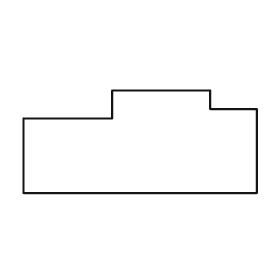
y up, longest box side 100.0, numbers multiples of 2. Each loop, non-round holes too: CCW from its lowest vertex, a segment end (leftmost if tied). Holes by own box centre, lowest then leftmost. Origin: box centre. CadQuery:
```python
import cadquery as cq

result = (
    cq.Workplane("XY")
    .moveTo(-50.0, -22.0)
    .lineTo(50.0, -22.0)
    .lineTo(50.0, 14.0)
    .lineTo(30.0, 14.0)
    .lineTo(30.0, 22.0)
    .lineTo(-12.0, 22.0)
    .lineTo(-12.0, 10.0)
    .lineTo(-50.0, 10.0)
    .close()
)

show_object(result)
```